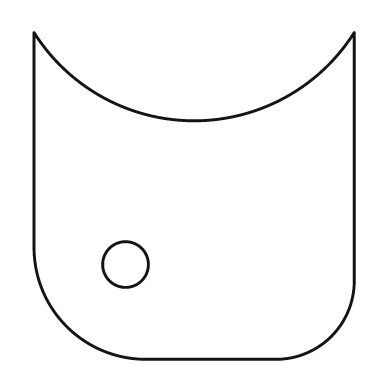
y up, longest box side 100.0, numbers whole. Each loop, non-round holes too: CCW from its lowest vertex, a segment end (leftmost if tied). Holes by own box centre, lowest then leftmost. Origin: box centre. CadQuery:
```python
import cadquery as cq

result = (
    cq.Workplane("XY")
    .moveTo(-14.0, -50.0)
    .lineTo(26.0, -50.0)
    .threePointArc((42.0, -43.0), (49.0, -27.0))
    .lineTo(49.0, 50.0)
    .threePointArc((0.0, 23.0), (-49.0, 50.0))
    .lineTo(-49.0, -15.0)
    .threePointArc((-39.0, -40.0), (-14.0, -50.0))
    .close()
    .moveTo(-21.0, -21.0)
    .circle(7.0)
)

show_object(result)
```